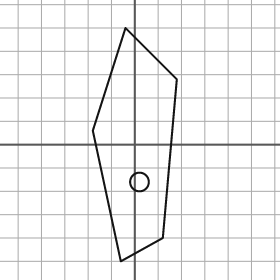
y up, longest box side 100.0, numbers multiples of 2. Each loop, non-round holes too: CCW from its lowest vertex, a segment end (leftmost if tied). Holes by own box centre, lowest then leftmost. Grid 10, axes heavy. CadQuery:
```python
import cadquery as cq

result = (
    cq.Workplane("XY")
    .moveTo(-6.0, -50.0)
    .lineTo(12.0, -40.0)
    .lineTo(18.0, 28.0)
    .lineTo(-4.0, 50.0)
    .lineTo(-18.0, 6.0)
    .close()
    .moveTo(2.0, -16.0)
    .circle(4.0)
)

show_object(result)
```